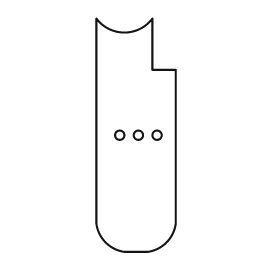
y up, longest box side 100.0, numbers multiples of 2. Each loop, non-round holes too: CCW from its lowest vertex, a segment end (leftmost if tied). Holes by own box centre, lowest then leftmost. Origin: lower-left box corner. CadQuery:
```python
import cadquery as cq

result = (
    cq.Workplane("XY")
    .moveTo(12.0, 0.0)
    .lineTo(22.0, 0.0)
    .threePointArc((30.0, 4.0), (34.0, 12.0))
    .lineTo(34.0, 78.0)
    .lineTo(24.0, 78.0)
    .lineTo(24.0, 100.0)
    .threePointArc((12.0, 94.0), (0.0, 100.0))
    .lineTo(0.0, 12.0)
    .threePointArc((4.0, 4.0), (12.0, 0.0))
    .close()
    .moveTo(10.0, 50.0)
    .circle(2.0)
    .moveTo(18.0, 50.0)
    .circle(2.0)
    .moveTo(26.0, 50.0)
    .circle(2.0)
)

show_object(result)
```